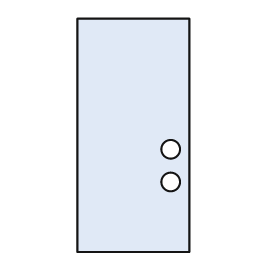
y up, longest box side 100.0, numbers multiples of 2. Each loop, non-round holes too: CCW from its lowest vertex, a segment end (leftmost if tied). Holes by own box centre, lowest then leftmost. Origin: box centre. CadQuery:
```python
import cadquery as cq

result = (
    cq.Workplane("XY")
    .moveTo(-24.0, -50.0)
    .lineTo(24.0, -50.0)
    .lineTo(24.0, 50.0)
    .lineTo(-24.0, 50.0)
    .close()
    .moveTo(16.0, -20.0)
    .circle(4.0)
    .moveTo(16.0, -6.0)
    .circle(4.0)
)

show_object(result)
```